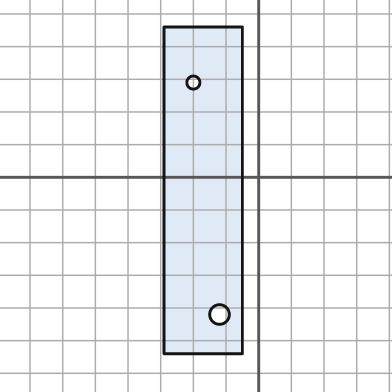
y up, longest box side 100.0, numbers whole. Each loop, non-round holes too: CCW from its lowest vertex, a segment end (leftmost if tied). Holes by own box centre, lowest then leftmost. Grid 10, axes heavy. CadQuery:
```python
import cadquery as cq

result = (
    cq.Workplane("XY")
    .moveTo(-29.0, -54.0)
    .lineTo(-5.0, -54.0)
    .lineTo(-5.0, 46.0)
    .lineTo(-29.0, 46.0)
    .close()
    .moveTo(-12.0, -42.0)
    .circle(3.0)
    .moveTo(-20.0, 29.0)
    .circle(2.0)
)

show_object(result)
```